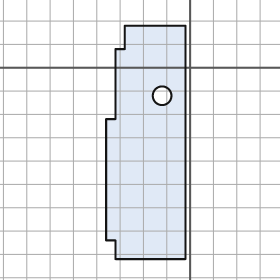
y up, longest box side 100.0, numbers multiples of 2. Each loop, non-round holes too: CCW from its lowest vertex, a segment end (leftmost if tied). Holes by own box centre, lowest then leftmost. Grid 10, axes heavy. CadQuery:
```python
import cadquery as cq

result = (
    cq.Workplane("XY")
    .moveTo(-32.0, -82.0)
    .lineTo(-2.0, -82.0)
    .lineTo(-2.0, 18.0)
    .lineTo(-28.0, 18.0)
    .lineTo(-28.0, 8.0)
    .lineTo(-32.0, 8.0)
    .lineTo(-32.0, -22.0)
    .lineTo(-36.0, -22.0)
    .lineTo(-36.0, -74.0)
    .lineTo(-32.0, -74.0)
    .close()
    .moveTo(-12.0, -12.0)
    .circle(4.0)
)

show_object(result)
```